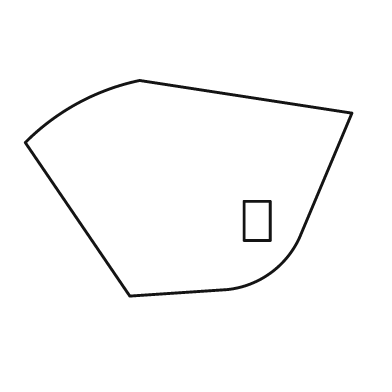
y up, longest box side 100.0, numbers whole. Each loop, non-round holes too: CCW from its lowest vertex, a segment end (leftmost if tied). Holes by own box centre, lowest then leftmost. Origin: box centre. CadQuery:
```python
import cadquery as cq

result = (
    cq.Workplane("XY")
    .moveTo(-18.0, -33.0)
    .lineTo(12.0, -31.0)
    .threePointArc((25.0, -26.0), (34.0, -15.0))
    .lineTo(50.0, 23.0)
    .lineTo(-15.0, 33.0)
    .threePointArc((-34.0, 26.0), (-50.0, 14.0))
    .close()
    .moveTo(17.0, -16.0)
    .lineTo(25.0, -16.0)
    .lineTo(25.0, -4.0)
    .lineTo(17.0, -4.0)
    .close()
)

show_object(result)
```